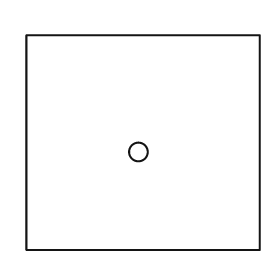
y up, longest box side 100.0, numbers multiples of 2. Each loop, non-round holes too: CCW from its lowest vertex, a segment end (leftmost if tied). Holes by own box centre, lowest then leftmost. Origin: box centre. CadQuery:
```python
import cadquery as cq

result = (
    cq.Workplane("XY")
    .moveTo(-50.0, -46.0)
    .lineTo(50.0, -46.0)
    .lineTo(50.0, 46.0)
    .lineTo(-50.0, 46.0)
    .close()
    .moveTo(-2.0, -4.0)
    .circle(4.0)
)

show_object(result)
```